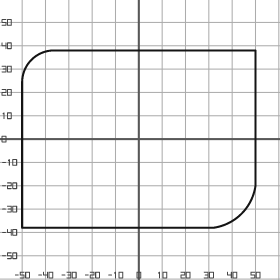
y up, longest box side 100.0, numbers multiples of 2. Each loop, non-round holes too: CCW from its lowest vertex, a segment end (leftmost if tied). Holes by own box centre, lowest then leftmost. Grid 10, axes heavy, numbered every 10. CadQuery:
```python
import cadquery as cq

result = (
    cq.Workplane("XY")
    .moveTo(-50.0, -38.0)
    .lineTo(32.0, -38.0)
    .threePointArc((44.0, -32.0), (50.0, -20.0))
    .lineTo(50.0, 38.0)
    .lineTo(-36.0, 38.0)
    .threePointArc((-46.0, 34.0), (-50.0, 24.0))
    .close()
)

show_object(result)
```